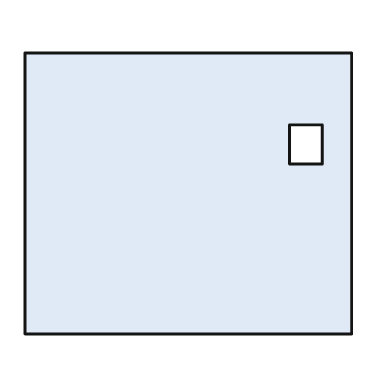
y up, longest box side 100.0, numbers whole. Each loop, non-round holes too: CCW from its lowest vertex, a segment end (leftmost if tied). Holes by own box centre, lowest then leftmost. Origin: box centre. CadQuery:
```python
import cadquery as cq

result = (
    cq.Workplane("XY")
    .moveTo(-50.0, -43.0)
    .lineTo(50.0, -43.0)
    .lineTo(50.0, 43.0)
    .lineTo(-50.0, 43.0)
    .close()
    .moveTo(31.0, 9.0)
    .lineTo(41.0, 9.0)
    .lineTo(41.0, 21.0)
    .lineTo(31.0, 21.0)
    .close()
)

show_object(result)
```